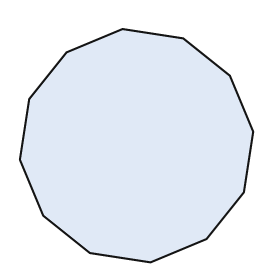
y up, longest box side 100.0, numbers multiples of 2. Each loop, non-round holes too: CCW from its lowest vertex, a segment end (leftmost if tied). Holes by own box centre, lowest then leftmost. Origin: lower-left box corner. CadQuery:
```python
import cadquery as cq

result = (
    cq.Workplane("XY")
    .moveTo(56.0, 0.0)
    .lineTo(80.0, 10.0)
    .lineTo(96.0, 30.0)
    .lineTo(100.0, 56.0)
    .lineTo(90.0, 80.0)
    .lineTo(70.0, 96.0)
    .lineTo(44.0, 100.0)
    .lineTo(20.0, 90.0)
    .lineTo(4.0, 70.0)
    .lineTo(0.0, 44.0)
    .lineTo(10.0, 20.0)
    .lineTo(30.0, 4.0)
    .close()
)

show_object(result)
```